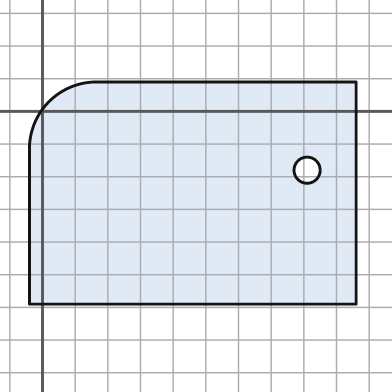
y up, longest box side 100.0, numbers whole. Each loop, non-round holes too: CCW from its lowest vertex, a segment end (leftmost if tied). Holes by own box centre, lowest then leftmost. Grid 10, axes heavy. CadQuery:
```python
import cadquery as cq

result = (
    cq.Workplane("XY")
    .moveTo(-4.0, -59.0)
    .lineTo(96.0, -59.0)
    .lineTo(96.0, 9.0)
    .lineTo(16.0, 9.0)
    .threePointArc((2.0, 3.0), (-4.0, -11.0))
    .close()
    .moveTo(81.0, -18.0)
    .circle(4.0)
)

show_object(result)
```